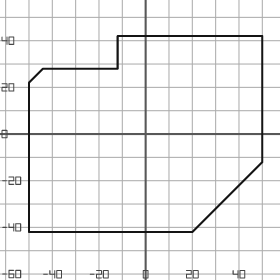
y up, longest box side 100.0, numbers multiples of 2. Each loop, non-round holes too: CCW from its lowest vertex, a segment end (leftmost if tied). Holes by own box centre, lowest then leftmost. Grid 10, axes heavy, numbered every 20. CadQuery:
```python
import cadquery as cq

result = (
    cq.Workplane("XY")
    .moveTo(-50.0, -42.0)
    .lineTo(20.0, -42.0)
    .lineTo(50.0, -12.0)
    .lineTo(50.0, 42.0)
    .lineTo(-12.0, 42.0)
    .lineTo(-12.0, 28.0)
    .lineTo(-44.0, 28.0)
    .lineTo(-50.0, 22.0)
    .close()
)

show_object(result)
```